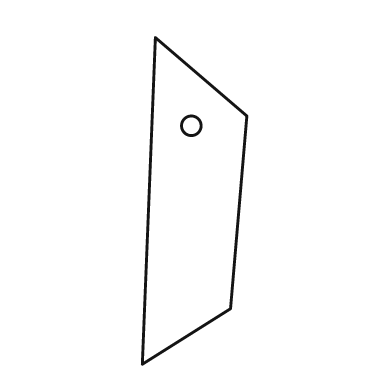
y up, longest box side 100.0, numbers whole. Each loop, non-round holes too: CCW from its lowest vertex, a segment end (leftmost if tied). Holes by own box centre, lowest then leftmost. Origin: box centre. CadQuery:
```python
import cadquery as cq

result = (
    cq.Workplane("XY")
    .moveTo(-16.0, -50.0)
    .lineTo(11.0, -33.0)
    .lineTo(16.0, 26.0)
    .lineTo(-12.0, 50.0)
    .close()
    .moveTo(-1.0, 23.0)
    .circle(3.0)
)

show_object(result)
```